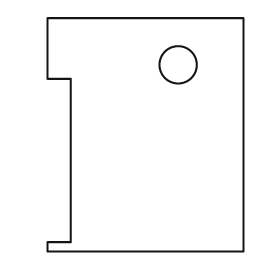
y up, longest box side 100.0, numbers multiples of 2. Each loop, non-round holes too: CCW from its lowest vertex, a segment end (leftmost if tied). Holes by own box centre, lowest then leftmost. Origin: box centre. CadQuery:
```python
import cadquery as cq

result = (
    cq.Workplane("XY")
    .moveTo(-42.0, -50.0)
    .lineTo(42.0, -50.0)
    .lineTo(42.0, 50.0)
    .lineTo(-42.0, 50.0)
    .lineTo(-42.0, 24.0)
    .lineTo(-32.0, 24.0)
    .lineTo(-32.0, -46.0)
    .lineTo(-42.0, -46.0)
    .close()
    .moveTo(14.0, 30.0)
    .circle(8.0)
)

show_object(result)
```